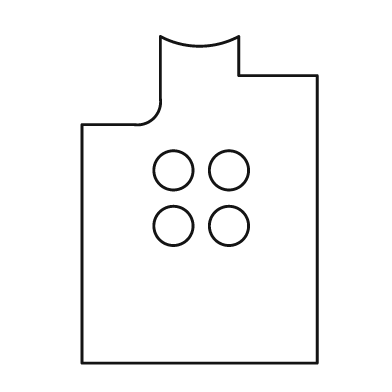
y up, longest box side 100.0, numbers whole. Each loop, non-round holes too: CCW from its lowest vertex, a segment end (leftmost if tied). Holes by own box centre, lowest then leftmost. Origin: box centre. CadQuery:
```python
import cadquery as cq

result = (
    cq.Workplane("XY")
    .moveTo(-36.0, -50.0)
    .lineTo(36.0, -50.0)
    .lineTo(36.0, 38.0)
    .lineTo(12.0, 38.0)
    .lineTo(12.0, 50.0)
    .threePointArc((0.0, 47.0), (-12.0, 50.0))
    .lineTo(-12.0, 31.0)
    .threePointArc((-14.0, 25.0), (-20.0, 23.0))
    .lineTo(-36.0, 23.0)
    .close()
    .moveTo(-8.0, -8.0)
    .circle(6.0)
    .moveTo(9.0, -8.0)
    .circle(6.0)
    .moveTo(-8.0, 9.0)
    .circle(6.0)
    .moveTo(9.0, 9.0)
    .circle(6.0)
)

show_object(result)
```